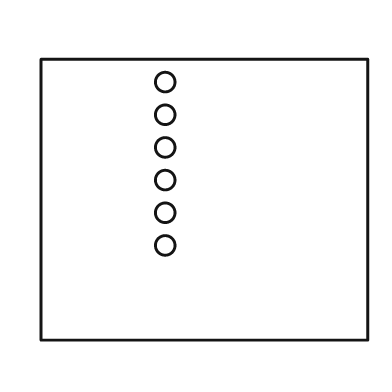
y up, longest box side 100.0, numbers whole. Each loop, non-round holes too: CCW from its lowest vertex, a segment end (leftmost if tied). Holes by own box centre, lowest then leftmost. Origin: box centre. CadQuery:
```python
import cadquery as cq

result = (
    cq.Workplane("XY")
    .moveTo(-50.0, -43.0)
    .lineTo(50.0, -43.0)
    .lineTo(50.0, 43.0)
    .lineTo(-50.0, 43.0)
    .close()
    .moveTo(-12.0, -14.0)
    .circle(3.0)
    .moveTo(-12.0, -4.0)
    .circle(3.0)
    .moveTo(-12.0, 6.0)
    .circle(3.0)
    .moveTo(-12.0, 16.0)
    .circle(3.0)
    .moveTo(-12.0, 26.0)
    .circle(3.0)
    .moveTo(-12.0, 36.0)
    .circle(3.0)
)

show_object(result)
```